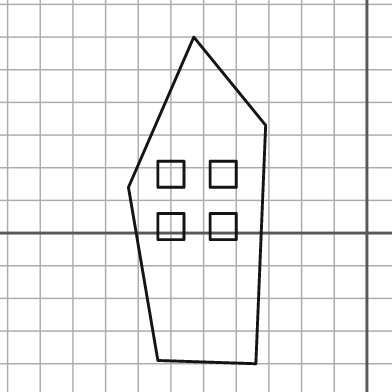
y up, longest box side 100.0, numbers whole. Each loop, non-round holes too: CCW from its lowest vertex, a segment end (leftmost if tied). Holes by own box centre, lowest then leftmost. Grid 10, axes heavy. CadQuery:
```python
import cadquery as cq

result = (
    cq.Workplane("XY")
    .moveTo(-34.0, -40.0)
    .lineTo(-31.0, 33.0)
    .lineTo(-53.0, 60.0)
    .lineTo(-73.0, 14.0)
    .lineTo(-64.0, -39.0)
    .close()
    .moveTo(-64.0, -2.0)
    .lineTo(-56.0, -2.0)
    .lineTo(-56.0, 6.0)
    .lineTo(-64.0, 6.0)
    .close()
    .moveTo(-48.0, -2.0)
    .lineTo(-40.0, -2.0)
    .lineTo(-40.0, 6.0)
    .lineTo(-48.0, 6.0)
    .close()
    .moveTo(-64.0, 14.0)
    .lineTo(-56.0, 14.0)
    .lineTo(-56.0, 22.0)
    .lineTo(-64.0, 22.0)
    .close()
    .moveTo(-48.0, 14.0)
    .lineTo(-40.0, 14.0)
    .lineTo(-40.0, 22.0)
    .lineTo(-48.0, 22.0)
    .close()
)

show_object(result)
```